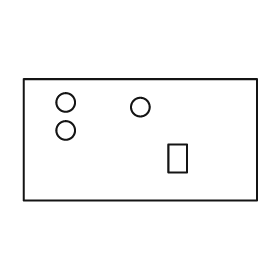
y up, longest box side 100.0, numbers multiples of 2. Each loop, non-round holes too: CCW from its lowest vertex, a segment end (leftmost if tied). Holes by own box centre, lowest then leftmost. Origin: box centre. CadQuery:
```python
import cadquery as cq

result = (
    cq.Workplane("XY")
    .moveTo(-50.0, -26.0)
    .lineTo(50.0, -26.0)
    .lineTo(50.0, 26.0)
    .lineTo(-50.0, 26.0)
    .close()
    .moveTo(12.0, -14.0)
    .lineTo(20.0, -14.0)
    .lineTo(20.0, -2.0)
    .lineTo(12.0, -2.0)
    .close()
    .moveTo(-32.0, 4.0)
    .circle(4.0)
    .moveTo(0.0, 14.0)
    .circle(4.0)
    .moveTo(-32.0, 16.0)
    .circle(4.0)
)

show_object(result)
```